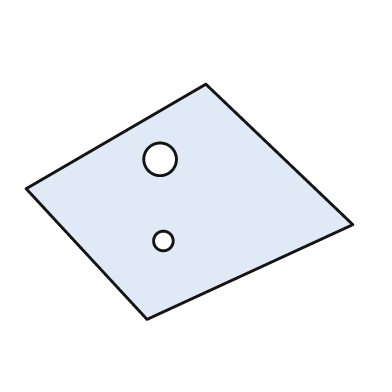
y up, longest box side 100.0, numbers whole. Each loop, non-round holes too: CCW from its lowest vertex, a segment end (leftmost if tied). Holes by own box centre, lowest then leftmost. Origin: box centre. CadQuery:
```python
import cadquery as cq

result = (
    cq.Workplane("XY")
    .moveTo(-13.0, -36.0)
    .lineTo(50.0, -7.0)
    .lineTo(5.0, 36.0)
    .lineTo(-50.0, 4.0)
    .close()
    .moveTo(-8.0, -12.0)
    .circle(3.0)
    .moveTo(-9.0, 13.0)
    .circle(5.0)
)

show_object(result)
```